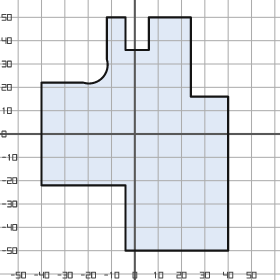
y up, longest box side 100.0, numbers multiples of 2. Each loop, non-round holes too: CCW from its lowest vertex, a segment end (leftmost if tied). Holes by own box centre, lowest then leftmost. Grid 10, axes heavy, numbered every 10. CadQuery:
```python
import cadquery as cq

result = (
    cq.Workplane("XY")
    .moveTo(-4.0, -50.0)
    .lineTo(40.0, -50.0)
    .lineTo(40.0, 16.0)
    .lineTo(24.0, 16.0)
    .lineTo(24.0, 50.0)
    .lineTo(6.0, 50.0)
    .lineTo(6.0, 36.0)
    .lineTo(-4.0, 36.0)
    .lineTo(-4.0, 50.0)
    .lineTo(-12.0, 50.0)
    .lineTo(-12.0, 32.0)
    .threePointArc((-14.0, 24.0), (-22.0, 22.0))
    .lineTo(-40.0, 22.0)
    .lineTo(-40.0, -22.0)
    .lineTo(-4.0, -22.0)
    .close()
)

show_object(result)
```